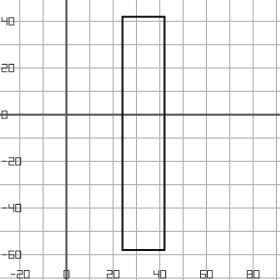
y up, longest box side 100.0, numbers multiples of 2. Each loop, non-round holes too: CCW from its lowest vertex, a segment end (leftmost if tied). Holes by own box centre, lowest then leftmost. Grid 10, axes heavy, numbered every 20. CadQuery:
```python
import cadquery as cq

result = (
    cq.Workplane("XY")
    .moveTo(24.0, -58.0)
    .lineTo(42.0, -58.0)
    .lineTo(42.0, 42.0)
    .lineTo(24.0, 42.0)
    .close()
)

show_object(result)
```